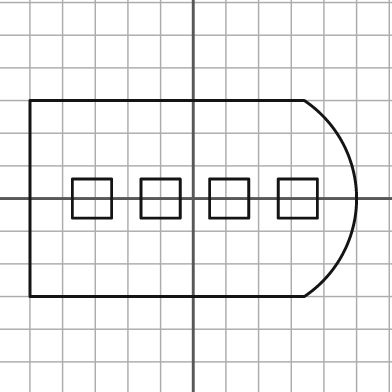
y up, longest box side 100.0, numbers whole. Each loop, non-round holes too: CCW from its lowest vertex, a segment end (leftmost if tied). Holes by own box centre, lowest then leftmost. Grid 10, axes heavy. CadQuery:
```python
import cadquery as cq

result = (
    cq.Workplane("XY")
    .moveTo(-50.0, -30.0)
    .lineTo(34.0, -30.0)
    .threePointArc((50.0, 0.0), (34.0, 30.0))
    .lineTo(-50.0, 30.0)
    .close()
    .moveTo(-37.0, -6.0)
    .lineTo(-25.0, -6.0)
    .lineTo(-25.0, 6.0)
    .lineTo(-37.0, 6.0)
    .close()
    .moveTo(-16.0, -6.0)
    .lineTo(-4.0, -6.0)
    .lineTo(-4.0, 6.0)
    .lineTo(-16.0, 6.0)
    .close()
    .moveTo(5.0, -6.0)
    .lineTo(17.0, -6.0)
    .lineTo(17.0, 6.0)
    .lineTo(5.0, 6.0)
    .close()
    .moveTo(26.0, -6.0)
    .lineTo(38.0, -6.0)
    .lineTo(38.0, 6.0)
    .lineTo(26.0, 6.0)
    .close()
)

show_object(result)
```